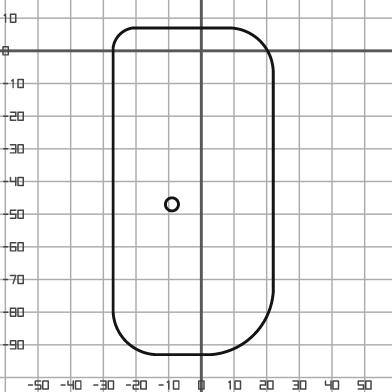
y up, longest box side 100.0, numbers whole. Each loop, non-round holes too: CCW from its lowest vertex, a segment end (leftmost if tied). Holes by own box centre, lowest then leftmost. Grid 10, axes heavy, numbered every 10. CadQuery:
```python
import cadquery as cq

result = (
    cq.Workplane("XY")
    .moveTo(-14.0, -93.0)
    .lineTo(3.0, -93.0)
    .threePointArc((16.0, -87.0), (22.0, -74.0))
    .lineTo(22.0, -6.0)
    .threePointArc((18.0, 3.0), (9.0, 7.0))
    .lineTo(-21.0, 7.0)
    .threePointArc((-25.0, 5.0), (-27.0, 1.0))
    .lineTo(-27.0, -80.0)
    .threePointArc((-23.0, -89.0), (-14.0, -93.0))
    .close()
    .moveTo(-9.0, -47.0)
    .circle(2.0)
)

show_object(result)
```